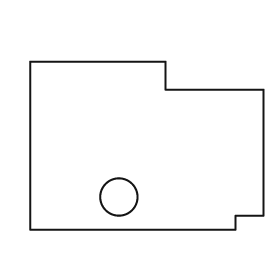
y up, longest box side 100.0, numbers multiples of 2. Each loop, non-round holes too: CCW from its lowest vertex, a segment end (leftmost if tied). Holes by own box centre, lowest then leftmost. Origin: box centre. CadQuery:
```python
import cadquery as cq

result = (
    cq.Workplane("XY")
    .moveTo(-50.0, -36.0)
    .lineTo(38.0, -36.0)
    .lineTo(38.0, -30.0)
    .lineTo(50.0, -30.0)
    .lineTo(50.0, 24.0)
    .lineTo(8.0, 24.0)
    .lineTo(8.0, 36.0)
    .lineTo(-50.0, 36.0)
    .close()
    .moveTo(-12.0, -22.0)
    .circle(8.0)
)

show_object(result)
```